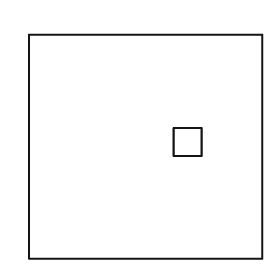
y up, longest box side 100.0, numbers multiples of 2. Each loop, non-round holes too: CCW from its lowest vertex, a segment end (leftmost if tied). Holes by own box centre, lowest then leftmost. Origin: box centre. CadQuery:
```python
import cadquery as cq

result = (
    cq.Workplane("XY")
    .moveTo(-50.0, -48.0)
    .lineTo(50.0, -48.0)
    .lineTo(50.0, 48.0)
    .lineTo(-50.0, 48.0)
    .close()
    .moveTo(12.0, -4.0)
    .lineTo(24.0, -4.0)
    .lineTo(24.0, 8.0)
    .lineTo(12.0, 8.0)
    .close()
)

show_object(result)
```